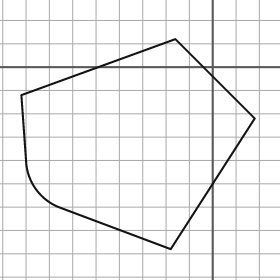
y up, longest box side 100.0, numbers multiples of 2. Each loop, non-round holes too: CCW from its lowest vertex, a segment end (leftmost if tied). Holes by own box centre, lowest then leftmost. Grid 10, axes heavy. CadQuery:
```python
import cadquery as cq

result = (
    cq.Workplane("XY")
    .moveTo(-18.0, -78.0)
    .lineTo(18.0, -22.0)
    .lineTo(-16.0, 12.0)
    .lineTo(-82.0, -12.0)
    .lineTo(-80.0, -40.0)
    .threePointArc((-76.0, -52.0), (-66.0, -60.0))
    .close()
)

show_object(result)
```